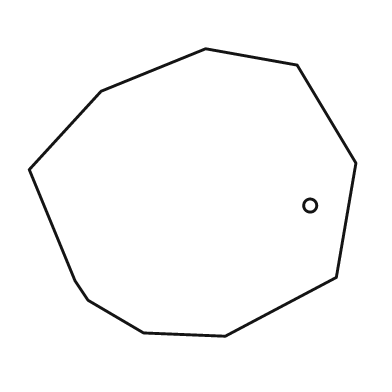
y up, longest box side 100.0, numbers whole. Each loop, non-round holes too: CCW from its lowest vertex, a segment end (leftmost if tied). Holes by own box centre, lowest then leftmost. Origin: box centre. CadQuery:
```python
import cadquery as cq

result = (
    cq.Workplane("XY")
    .moveTo(10.0, -44.0)
    .lineTo(44.0, -26.0)
    .lineTo(50.0, 9.0)
    .lineTo(32.0, 39.0)
    .lineTo(4.0, 44.0)
    .lineTo(-28.0, 31.0)
    .lineTo(-50.0, 7.0)
    .lineTo(-36.0, -27.0)
    .lineTo(-32.0, -33.0)
    .lineTo(-15.0, -43.0)
    .close()
    .moveTo(36.0, -4.0)
    .circle(2.0)
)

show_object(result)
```